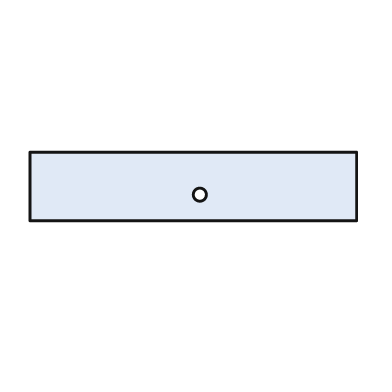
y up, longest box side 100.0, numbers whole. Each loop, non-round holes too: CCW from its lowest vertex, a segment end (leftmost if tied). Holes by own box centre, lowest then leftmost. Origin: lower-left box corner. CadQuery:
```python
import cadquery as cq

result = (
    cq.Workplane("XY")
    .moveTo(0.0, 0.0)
    .lineTo(100.0, 0.0)
    .lineTo(100.0, 21.0)
    .lineTo(0.0, 21.0)
    .close()
    .moveTo(52.0, 8.0)
    .circle(2.0)
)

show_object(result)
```